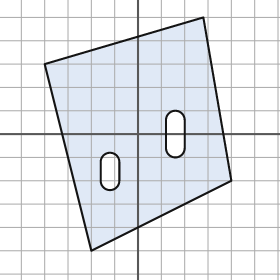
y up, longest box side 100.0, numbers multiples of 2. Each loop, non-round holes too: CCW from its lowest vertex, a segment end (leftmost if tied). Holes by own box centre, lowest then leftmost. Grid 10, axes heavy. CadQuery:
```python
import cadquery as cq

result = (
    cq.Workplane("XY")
    .moveTo(-20.0, -50.0)
    .lineTo(40.0, -20.0)
    .lineTo(28.0, 50.0)
    .lineTo(-40.0, 30.0)
    .close()
    .moveTo(-16.0, -20.0)
    .threePointArc((-12.0, -24.0), (-8.0, -20.0))
    .lineTo(-8.0, -12.0)
    .threePointArc((-12.0, -8.0), (-16.0, -12.0))
    .close()
    .moveTo(12.0, -6.0)
    .threePointArc((16.0, -10.0), (20.0, -6.0))
    .lineTo(20.0, 6.0)
    .threePointArc((16.0, 10.0), (12.0, 6.0))
    .close()
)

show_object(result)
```